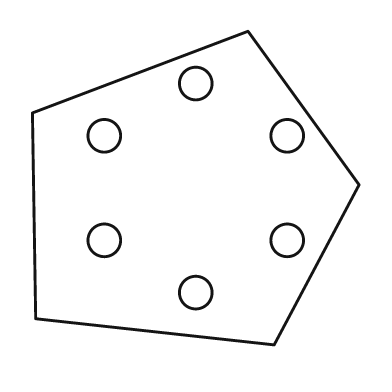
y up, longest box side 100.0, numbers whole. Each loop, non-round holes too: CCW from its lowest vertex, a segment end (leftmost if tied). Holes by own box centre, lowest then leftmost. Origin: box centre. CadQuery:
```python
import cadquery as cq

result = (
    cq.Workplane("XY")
    .moveTo(24.0, -48.0)
    .lineTo(50.0, 1.0)
    .lineTo(16.0, 48.0)
    .lineTo(-50.0, 23.0)
    .lineTo(-49.0, -40.0)
    .close()
    .moveTo(0.0, -32.0)
    .circle(5.0)
    .moveTo(-28.0, -16.0)
    .circle(5.0)
    .moveTo(28.0, -16.0)
    .circle(5.0)
    .moveTo(-28.0, 16.0)
    .circle(5.0)
    .moveTo(28.0, 16.0)
    .circle(5.0)
    .moveTo(0.0, 32.0)
    .circle(5.0)
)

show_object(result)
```